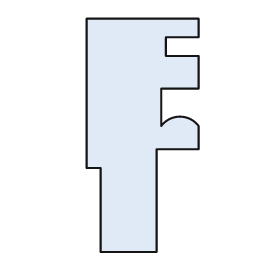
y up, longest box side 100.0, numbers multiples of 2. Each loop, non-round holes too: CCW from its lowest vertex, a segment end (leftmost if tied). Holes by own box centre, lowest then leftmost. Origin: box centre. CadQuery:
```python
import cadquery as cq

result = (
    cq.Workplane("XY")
    .moveTo(-18.0, -50.0)
    .lineTo(6.0, -50.0)
    .lineTo(6.0, -6.0)
    .lineTo(24.0, -6.0)
    .lineTo(24.0, 4.0)
    .threePointArc((16.0, 8.0), (8.0, 4.0))
    .lineTo(8.0, 20.0)
    .lineTo(24.0, 20.0)
    .lineTo(24.0, 34.0)
    .lineTo(10.0, 34.0)
    .lineTo(10.0, 42.0)
    .lineTo(24.0, 42.0)
    .lineTo(24.0, 50.0)
    .lineTo(-24.0, 50.0)
    .lineTo(-24.0, -14.0)
    .lineTo(-18.0, -14.0)
    .close()
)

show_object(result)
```